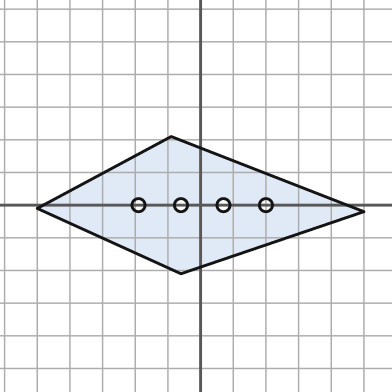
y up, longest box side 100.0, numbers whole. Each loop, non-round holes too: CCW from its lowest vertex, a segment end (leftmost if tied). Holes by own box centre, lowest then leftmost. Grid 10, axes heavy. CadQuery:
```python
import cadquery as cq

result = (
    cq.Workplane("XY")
    .moveTo(-6.0, -21.0)
    .lineTo(50.0, -2.0)
    .lineTo(-9.0, 21.0)
    .lineTo(-50.0, -1.0)
    .close()
    .moveTo(-19.0, 0.0)
    .circle(2.0)
    .moveTo(-6.0, 0.0)
    .circle(2.0)
    .moveTo(7.0, 0.0)
    .circle(2.0)
    .moveTo(20.0, 0.0)
    .circle(2.0)
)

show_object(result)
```